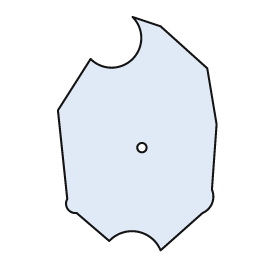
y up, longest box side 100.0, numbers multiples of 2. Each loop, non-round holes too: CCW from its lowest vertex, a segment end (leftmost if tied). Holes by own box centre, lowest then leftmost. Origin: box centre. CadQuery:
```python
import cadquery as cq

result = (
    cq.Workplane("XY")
    .moveTo(10.0, -50.0)
    .lineTo(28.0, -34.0)
    .threePointArc((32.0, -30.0), (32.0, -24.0))
    .lineTo(34.0, 4.0)
    .lineTo(30.0, 28.0)
    .lineTo(10.0, 46.0)
    .lineTo(-2.0, 50.0)
    .threePointArc((-2.0, 32.0), (-20.0, 32.0))
    .lineTo(-34.0, 10.0)
    .lineTo(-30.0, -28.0)
    .threePointArc((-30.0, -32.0), (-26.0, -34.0))
    .lineTo(-12.0, -46.0)
    .threePointArc((0.0, -42.0), (10.0, -50.0))
    .close()
    .moveTo(2.0, -6.0)
    .circle(2.0)
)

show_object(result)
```